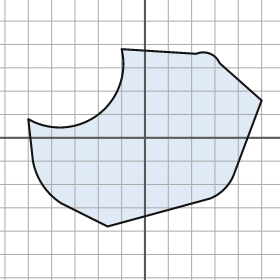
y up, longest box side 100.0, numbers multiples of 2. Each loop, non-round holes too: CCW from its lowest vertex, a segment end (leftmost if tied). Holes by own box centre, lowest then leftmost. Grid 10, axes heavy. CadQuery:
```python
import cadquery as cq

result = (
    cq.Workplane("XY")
    .moveTo(-16.0, -38.0)
    .lineTo(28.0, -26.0)
    .threePointArc((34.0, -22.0), (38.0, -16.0))
    .lineTo(50.0, 16.0)
    .lineTo(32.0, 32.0)
    .threePointArc((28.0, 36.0), (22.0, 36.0))
    .lineTo(-10.0, 38.0)
    .threePointArc((-20.0, 10.0), (-50.0, 8.0))
    .lineTo(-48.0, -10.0)
    .threePointArc((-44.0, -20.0), (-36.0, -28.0))
    .close()
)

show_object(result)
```